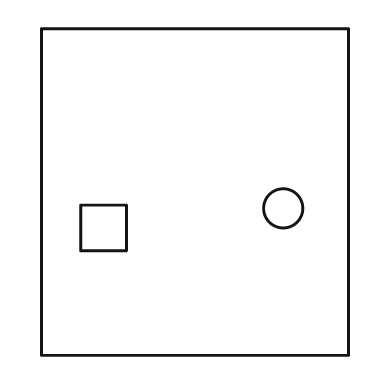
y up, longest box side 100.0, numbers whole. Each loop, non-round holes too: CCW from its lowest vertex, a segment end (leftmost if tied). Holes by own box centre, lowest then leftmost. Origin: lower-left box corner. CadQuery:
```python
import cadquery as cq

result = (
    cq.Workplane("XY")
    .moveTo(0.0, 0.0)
    .lineTo(94.0, 0.0)
    .lineTo(94.0, 100.0)
    .lineTo(0.0, 100.0)
    .close()
    .moveTo(12.0, 32.0)
    .lineTo(26.0, 32.0)
    .lineTo(26.0, 46.0)
    .lineTo(12.0, 46.0)
    .close()
    .moveTo(74.0, 45.0)
    .circle(6.0)
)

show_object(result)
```